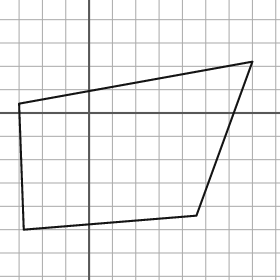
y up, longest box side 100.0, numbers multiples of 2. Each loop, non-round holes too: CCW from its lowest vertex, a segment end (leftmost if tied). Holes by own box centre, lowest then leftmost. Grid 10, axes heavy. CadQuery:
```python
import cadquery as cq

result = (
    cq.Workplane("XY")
    .moveTo(-28.0, -50.0)
    .lineTo(46.0, -44.0)
    .lineTo(70.0, 22.0)
    .lineTo(-30.0, 4.0)
    .close()
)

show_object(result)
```